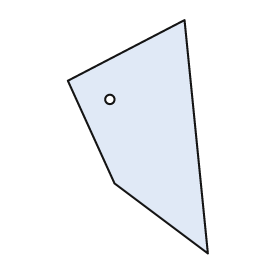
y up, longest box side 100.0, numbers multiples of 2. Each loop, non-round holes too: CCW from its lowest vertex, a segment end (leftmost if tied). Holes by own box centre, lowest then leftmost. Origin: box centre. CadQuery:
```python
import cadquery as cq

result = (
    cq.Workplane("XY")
    .moveTo(30.0, -50.0)
    .lineTo(20.0, 50.0)
    .lineTo(-30.0, 24.0)
    .lineTo(-10.0, -20.0)
    .close()
    .moveTo(-12.0, 16.0)
    .circle(2.0)
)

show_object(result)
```